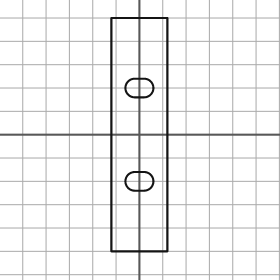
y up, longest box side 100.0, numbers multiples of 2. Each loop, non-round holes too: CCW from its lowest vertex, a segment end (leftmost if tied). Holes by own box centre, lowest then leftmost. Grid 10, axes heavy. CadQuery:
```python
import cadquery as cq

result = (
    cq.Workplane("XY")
    .moveTo(-12.0, -50.0)
    .lineTo(12.0, -50.0)
    .lineTo(12.0, 50.0)
    .lineTo(-12.0, 50.0)
    .close()
    .moveTo(-2.0, -24.0)
    .lineTo(2.0, -24.0)
    .threePointArc((6.0, -20.0), (2.0, -16.0))
    .lineTo(-2.0, -16.0)
    .threePointArc((-6.0, -20.0), (-2.0, -24.0))
    .close()
    .moveTo(-2.0, 16.0)
    .lineTo(2.0, 16.0)
    .threePointArc((6.0, 20.0), (2.0, 24.0))
    .lineTo(-2.0, 24.0)
    .threePointArc((-6.0, 20.0), (-2.0, 16.0))
    .close()
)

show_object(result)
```